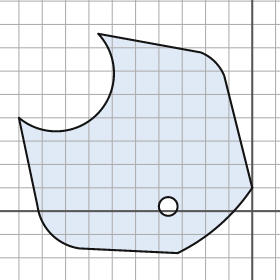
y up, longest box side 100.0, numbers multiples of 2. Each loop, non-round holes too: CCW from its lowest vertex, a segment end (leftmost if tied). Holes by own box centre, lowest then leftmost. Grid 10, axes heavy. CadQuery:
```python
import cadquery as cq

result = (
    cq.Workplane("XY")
    .moveTo(-32.0, -18.0)
    .threePointArc((-14.0, -6.0), (0.0, 10.0))
    .lineTo(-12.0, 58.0)
    .threePointArc((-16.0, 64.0), (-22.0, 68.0))
    .lineTo(-66.0, 76.0)
    .threePointArc((-66.0, 42.0), (-100.0, 40.0))
    .lineTo(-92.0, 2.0)
    .threePointArc((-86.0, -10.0), (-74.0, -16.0))
    .close()
    .moveTo(-36.0, 2.0)
    .circle(4.0)
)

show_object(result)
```